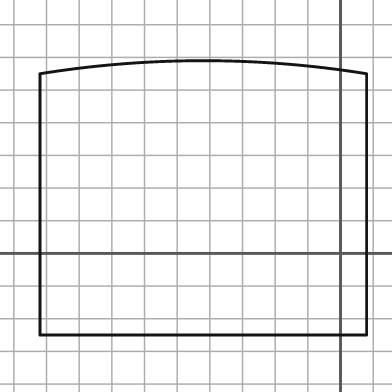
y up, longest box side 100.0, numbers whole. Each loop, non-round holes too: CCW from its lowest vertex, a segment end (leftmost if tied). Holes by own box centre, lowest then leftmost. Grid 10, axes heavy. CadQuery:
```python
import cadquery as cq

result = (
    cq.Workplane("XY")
    .moveTo(-92.0, -25.0)
    .lineTo(8.0, -25.0)
    .lineTo(8.0, 55.0)
    .threePointArc((-42.0, 59.0), (-92.0, 55.0))
    .close()
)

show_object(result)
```